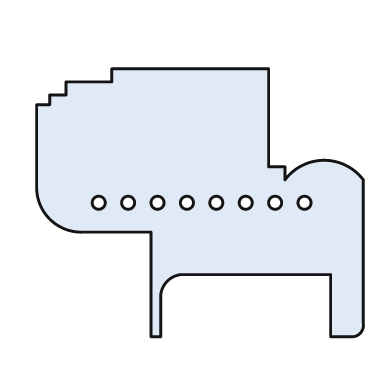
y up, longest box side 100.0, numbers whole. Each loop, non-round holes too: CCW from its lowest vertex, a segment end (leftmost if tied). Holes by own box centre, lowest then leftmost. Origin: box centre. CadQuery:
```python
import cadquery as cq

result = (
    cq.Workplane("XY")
    .moveTo(-15.0, -41.0)
    .lineTo(-12.0, -41.0)
    .lineTo(-12.0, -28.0)
    .threePointArc((-10.0, -24.0), (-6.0, -22.0))
    .lineTo(40.0, -22.0)
    .lineTo(40.0, -41.0)
    .lineTo(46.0, -41.0)
    .threePointArc((49.0, -40.0), (50.0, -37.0))
    .lineTo(50.0, 7.0)
    .threePointArc((38.0, 13.0), (26.0, 7.0))
    .lineTo(26.0, 11.0)
    .lineTo(21.0, 11.0)
    .lineTo(21.0, 41.0)
    .lineTo(-27.0, 41.0)
    .lineTo(-27.0, 37.0)
    .lineTo(-41.0, 37.0)
    .lineTo(-41.0, 33.0)
    .lineTo(-46.0, 33.0)
    .lineTo(-46.0, 30.0)
    .lineTo(-50.0, 30.0)
    .lineTo(-50.0, 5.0)
    .threePointArc((-46.0, -5.0), (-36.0, -9.0))
    .lineTo(-15.0, -9.0)
    .close()
    .moveTo(-31.0, 0.0)
    .circle(2.0)
    .moveTo(-22.0, 0.0)
    .circle(2.0)
    .moveTo(-13.0, 0.0)
    .circle(2.0)
    .moveTo(-4.0, 0.0)
    .circle(2.0)
    .moveTo(5.0, 0.0)
    .circle(2.0)
    .moveTo(14.0, 0.0)
    .circle(2.0)
    .moveTo(23.0, 0.0)
    .circle(2.0)
    .moveTo(32.0, 0.0)
    .circle(2.0)
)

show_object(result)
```